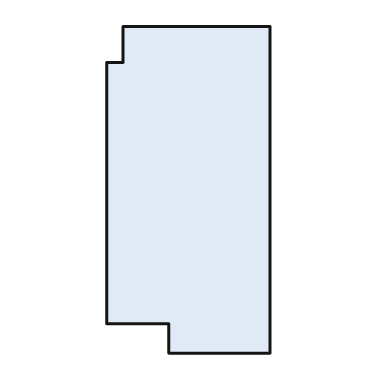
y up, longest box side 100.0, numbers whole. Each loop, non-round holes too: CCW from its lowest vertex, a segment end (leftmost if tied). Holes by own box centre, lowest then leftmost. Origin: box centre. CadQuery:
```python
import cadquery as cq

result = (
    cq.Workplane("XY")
    .moveTo(-6.0, -50.0)
    .lineTo(25.0, -50.0)
    .lineTo(25.0, 50.0)
    .lineTo(-20.0, 50.0)
    .lineTo(-20.0, 39.0)
    .lineTo(-25.0, 39.0)
    .lineTo(-25.0, -41.0)
    .lineTo(-6.0, -41.0)
    .close()
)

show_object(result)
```